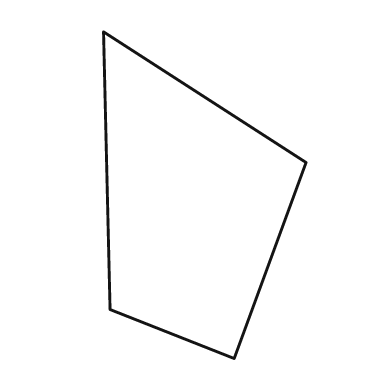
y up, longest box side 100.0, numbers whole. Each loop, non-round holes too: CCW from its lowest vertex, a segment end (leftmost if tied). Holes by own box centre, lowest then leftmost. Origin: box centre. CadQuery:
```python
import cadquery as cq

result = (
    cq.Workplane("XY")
    .moveTo(9.0, -50.0)
    .lineTo(31.0, 10.0)
    .lineTo(-31.0, 50.0)
    .lineTo(-29.0, -35.0)
    .close()
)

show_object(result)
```